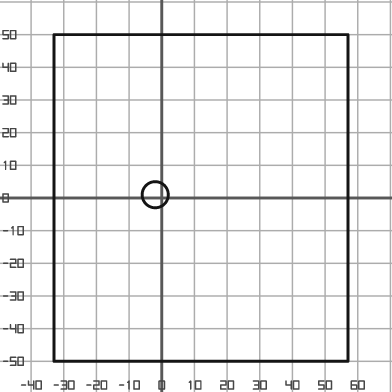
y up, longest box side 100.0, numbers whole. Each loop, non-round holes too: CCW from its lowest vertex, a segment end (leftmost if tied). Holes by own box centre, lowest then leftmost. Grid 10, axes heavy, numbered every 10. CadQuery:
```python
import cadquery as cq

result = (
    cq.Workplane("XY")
    .moveTo(-33.0, -50.0)
    .lineTo(57.0, -50.0)
    .lineTo(57.0, 50.0)
    .lineTo(-33.0, 50.0)
    .close()
    .moveTo(-2.0, 1.0)
    .circle(4.0)
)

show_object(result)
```